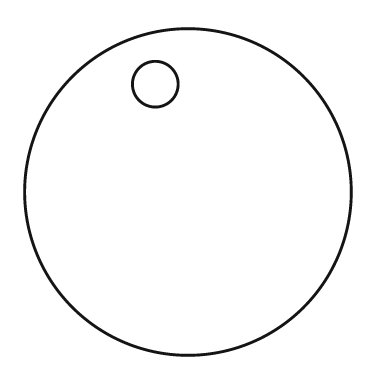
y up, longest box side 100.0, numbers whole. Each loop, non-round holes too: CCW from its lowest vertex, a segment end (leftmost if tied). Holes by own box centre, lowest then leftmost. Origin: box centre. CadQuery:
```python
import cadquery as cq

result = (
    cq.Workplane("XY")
    .moveTo(0.0, 0.0)
    .circle(50.0)
    .moveTo(-10.0, 33.0)
    .circle(7.0)
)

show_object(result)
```